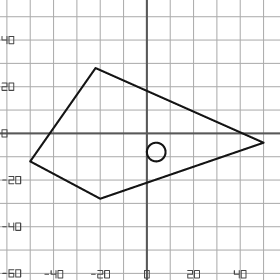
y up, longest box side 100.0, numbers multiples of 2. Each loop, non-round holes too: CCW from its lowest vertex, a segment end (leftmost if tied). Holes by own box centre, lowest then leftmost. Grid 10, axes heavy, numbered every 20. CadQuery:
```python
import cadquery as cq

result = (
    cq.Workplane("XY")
    .moveTo(-20.0, -28.0)
    .lineTo(50.0, -4.0)
    .lineTo(-22.0, 28.0)
    .lineTo(-50.0, -12.0)
    .close()
    .moveTo(4.0, -8.0)
    .circle(4.0)
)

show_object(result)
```